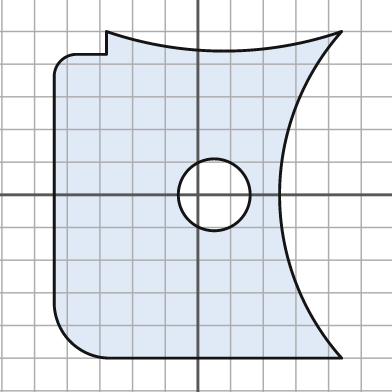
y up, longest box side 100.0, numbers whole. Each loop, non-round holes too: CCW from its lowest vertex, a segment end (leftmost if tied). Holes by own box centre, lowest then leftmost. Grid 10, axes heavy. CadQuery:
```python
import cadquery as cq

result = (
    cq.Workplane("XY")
    .moveTo(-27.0, -50.0)
    .lineTo(44.0, -50.0)
    .threePointArc((25.0, 0.0), (44.0, 50.0))
    .threePointArc((8.0, 44.0), (-28.0, 50.0))
    .lineTo(-28.0, 43.0)
    .lineTo(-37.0, 43.0)
    .threePointArc((-42.0, 41.0), (-44.0, 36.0))
    .lineTo(-44.0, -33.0)
    .threePointArc((-39.0, -45.0), (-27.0, -50.0))
    .close()
    .moveTo(5.0, 0.0)
    .circle(11.0)
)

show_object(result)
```